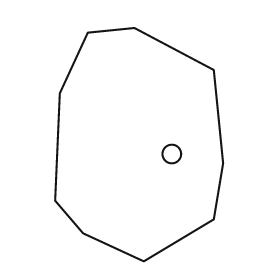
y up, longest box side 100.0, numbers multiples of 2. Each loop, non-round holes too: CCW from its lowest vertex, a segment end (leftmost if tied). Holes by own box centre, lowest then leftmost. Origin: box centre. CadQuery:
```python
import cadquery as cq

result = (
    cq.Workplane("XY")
    .moveTo(2.0, -50.0)
    .lineTo(32.0, -32.0)
    .lineTo(36.0, -8.0)
    .lineTo(32.0, 32.0)
    .lineTo(-2.0, 50.0)
    .lineTo(-22.0, 48.0)
    .lineTo(-34.0, 22.0)
    .lineTo(-36.0, -24.0)
    .lineTo(-24.0, -38.0)
    .close()
    .moveTo(14.0, -4.0)
    .circle(4.0)
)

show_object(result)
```